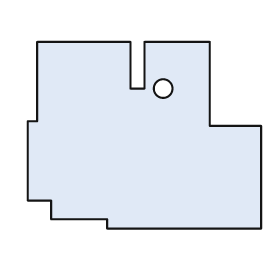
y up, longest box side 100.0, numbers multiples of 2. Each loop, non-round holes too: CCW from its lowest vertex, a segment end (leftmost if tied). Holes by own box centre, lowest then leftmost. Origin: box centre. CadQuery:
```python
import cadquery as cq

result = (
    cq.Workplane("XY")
    .moveTo(-16.0, -40.0)
    .lineTo(50.0, -40.0)
    .lineTo(50.0, 4.0)
    .lineTo(28.0, 4.0)
    .lineTo(28.0, 40.0)
    .lineTo(0.0, 40.0)
    .lineTo(0.0, 20.0)
    .lineTo(-6.0, 20.0)
    .lineTo(-6.0, 40.0)
    .lineTo(-46.0, 40.0)
    .lineTo(-46.0, 6.0)
    .lineTo(-50.0, 6.0)
    .lineTo(-50.0, -28.0)
    .lineTo(-40.0, -28.0)
    .lineTo(-40.0, -36.0)
    .lineTo(-16.0, -36.0)
    .close()
    .moveTo(8.0, 20.0)
    .circle(4.0)
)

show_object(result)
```